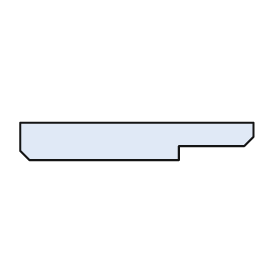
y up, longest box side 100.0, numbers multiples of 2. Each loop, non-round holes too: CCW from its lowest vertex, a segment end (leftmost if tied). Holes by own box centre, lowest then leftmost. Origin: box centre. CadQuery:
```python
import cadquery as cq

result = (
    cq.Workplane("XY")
    .moveTo(-46.0, -8.0)
    .lineTo(18.0, -8.0)
    .lineTo(18.0, -2.0)
    .lineTo(46.0, -2.0)
    .lineTo(50.0, 2.0)
    .lineTo(50.0, 8.0)
    .lineTo(-50.0, 8.0)
    .lineTo(-50.0, -4.0)
    .close()
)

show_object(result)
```